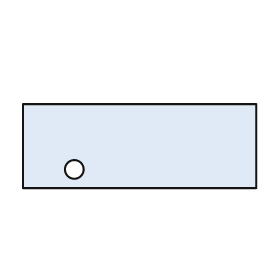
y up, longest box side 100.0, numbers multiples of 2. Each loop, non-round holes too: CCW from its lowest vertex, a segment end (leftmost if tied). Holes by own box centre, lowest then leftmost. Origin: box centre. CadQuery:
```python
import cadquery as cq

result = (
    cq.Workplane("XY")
    .moveTo(-50.0, -18.0)
    .lineTo(50.0, -18.0)
    .lineTo(50.0, 18.0)
    .lineTo(-50.0, 18.0)
    .close()
    .moveTo(-28.0, -10.0)
    .circle(4.0)
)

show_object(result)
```